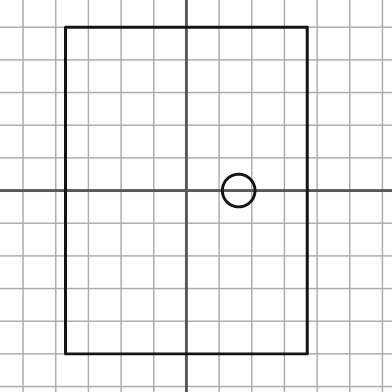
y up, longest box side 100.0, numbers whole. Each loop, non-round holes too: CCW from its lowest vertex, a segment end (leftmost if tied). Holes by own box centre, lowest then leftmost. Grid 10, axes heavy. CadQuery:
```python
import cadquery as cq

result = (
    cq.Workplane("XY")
    .moveTo(-37.0, -50.0)
    .lineTo(37.0, -50.0)
    .lineTo(37.0, 50.0)
    .lineTo(-37.0, 50.0)
    .close()
    .moveTo(16.0, 0.0)
    .circle(5.0)
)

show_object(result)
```